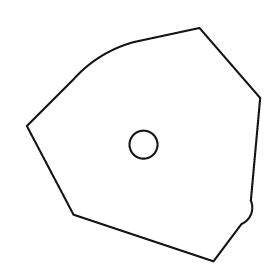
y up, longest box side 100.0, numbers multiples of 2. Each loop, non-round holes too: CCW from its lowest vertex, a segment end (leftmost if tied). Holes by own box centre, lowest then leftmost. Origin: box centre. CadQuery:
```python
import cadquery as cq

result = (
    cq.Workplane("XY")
    .moveTo(30.0, -50.0)
    .lineTo(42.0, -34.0)
    .threePointArc((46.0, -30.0), (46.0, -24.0))
    .lineTo(50.0, 20.0)
    .lineTo(24.0, 50.0)
    .lineTo(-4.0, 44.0)
    .threePointArc((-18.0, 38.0), (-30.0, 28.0))
    .lineTo(-50.0, 8.0)
    .lineTo(-30.0, -30.0)
    .close()
    .moveTo(0.0, 0.0)
    .circle(6.0)
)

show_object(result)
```